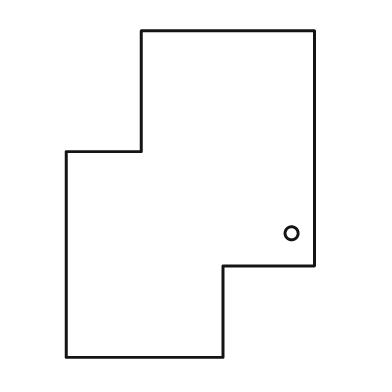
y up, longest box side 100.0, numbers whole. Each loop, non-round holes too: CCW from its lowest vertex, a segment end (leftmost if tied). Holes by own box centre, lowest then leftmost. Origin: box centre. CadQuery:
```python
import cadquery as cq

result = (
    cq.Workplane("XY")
    .moveTo(-38.0, -50.0)
    .lineTo(10.0, -50.0)
    .lineTo(10.0, -22.0)
    .lineTo(38.0, -22.0)
    .lineTo(38.0, 50.0)
    .lineTo(-15.0, 50.0)
    .lineTo(-15.0, 13.0)
    .lineTo(-38.0, 13.0)
    .close()
    .moveTo(31.0, -12.0)
    .circle(2.0)
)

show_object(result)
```